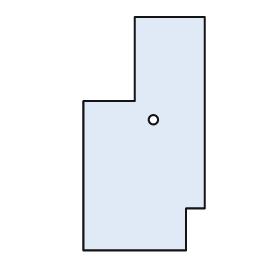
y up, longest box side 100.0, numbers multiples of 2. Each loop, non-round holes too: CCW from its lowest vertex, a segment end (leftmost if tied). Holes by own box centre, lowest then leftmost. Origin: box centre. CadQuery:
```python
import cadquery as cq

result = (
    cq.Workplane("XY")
    .moveTo(-26.0, -50.0)
    .lineTo(18.0, -50.0)
    .lineTo(18.0, -32.0)
    .lineTo(26.0, -32.0)
    .lineTo(26.0, 50.0)
    .lineTo(-4.0, 50.0)
    .lineTo(-4.0, 14.0)
    .lineTo(-26.0, 14.0)
    .close()
    .moveTo(4.0, 6.0)
    .circle(2.0)
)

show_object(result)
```